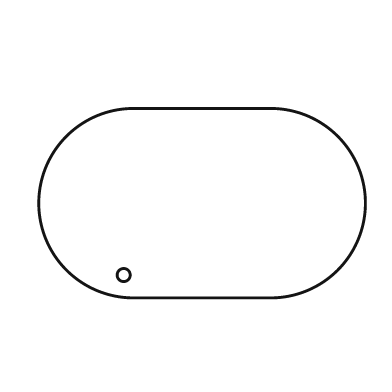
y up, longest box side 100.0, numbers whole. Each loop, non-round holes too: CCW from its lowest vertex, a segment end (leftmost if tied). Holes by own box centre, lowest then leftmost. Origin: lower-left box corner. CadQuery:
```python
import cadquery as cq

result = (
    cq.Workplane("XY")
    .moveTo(29.0, 0.0)
    .lineTo(71.0, 0.0)
    .threePointArc((100.0, 29.0), (71.0, 58.0))
    .lineTo(29.0, 58.0)
    .threePointArc((0.0, 29.0), (29.0, 0.0))
    .close()
    .moveTo(26.0, 7.0)
    .circle(2.0)
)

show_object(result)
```